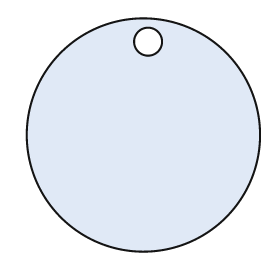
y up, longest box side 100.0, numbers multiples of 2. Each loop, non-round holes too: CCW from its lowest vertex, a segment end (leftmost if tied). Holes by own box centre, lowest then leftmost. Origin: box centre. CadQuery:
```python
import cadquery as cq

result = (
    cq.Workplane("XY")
    .moveTo(0.0, 0.0)
    .circle(50.0)
    .moveTo(2.0, 40.0)
    .circle(6.0)
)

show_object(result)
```